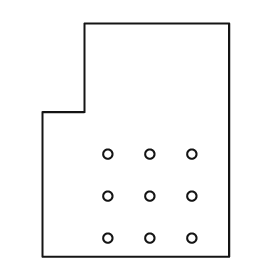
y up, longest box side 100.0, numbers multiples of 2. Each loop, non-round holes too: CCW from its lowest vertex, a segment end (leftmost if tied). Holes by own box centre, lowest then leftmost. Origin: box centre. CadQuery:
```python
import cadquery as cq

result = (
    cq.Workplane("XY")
    .moveTo(-40.0, -50.0)
    .lineTo(40.0, -50.0)
    .lineTo(40.0, 50.0)
    .lineTo(-22.0, 50.0)
    .lineTo(-22.0, 12.0)
    .lineTo(-40.0, 12.0)
    .close()
    .moveTo(-12.0, -42.0)
    .circle(2.0)
    .moveTo(6.0, -42.0)
    .circle(2.0)
    .moveTo(24.0, -42.0)
    .circle(2.0)
    .moveTo(-12.0, -24.0)
    .circle(2.0)
    .moveTo(6.0, -24.0)
    .circle(2.0)
    .moveTo(24.0, -24.0)
    .circle(2.0)
    .moveTo(-12.0, -6.0)
    .circle(2.0)
    .moveTo(6.0, -6.0)
    .circle(2.0)
    .moveTo(24.0, -6.0)
    .circle(2.0)
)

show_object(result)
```